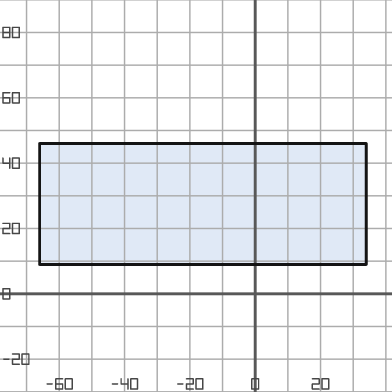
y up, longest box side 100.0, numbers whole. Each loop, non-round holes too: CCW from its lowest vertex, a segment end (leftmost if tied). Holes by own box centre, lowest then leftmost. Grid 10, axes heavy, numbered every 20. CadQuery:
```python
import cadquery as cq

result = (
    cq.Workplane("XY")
    .moveTo(-66.0, 9.0)
    .lineTo(34.0, 9.0)
    .lineTo(34.0, 46.0)
    .lineTo(-66.0, 46.0)
    .close()
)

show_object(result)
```